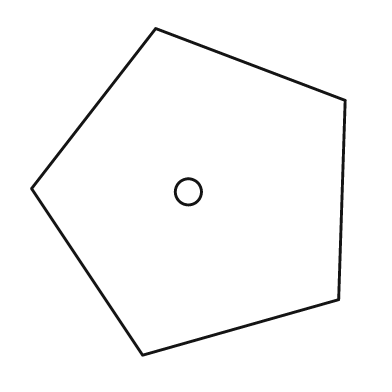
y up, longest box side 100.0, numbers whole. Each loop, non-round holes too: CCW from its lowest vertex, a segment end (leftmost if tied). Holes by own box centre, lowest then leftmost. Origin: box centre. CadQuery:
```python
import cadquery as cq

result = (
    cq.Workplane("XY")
    .moveTo(-14.0, -50.0)
    .lineTo(46.0, -33.0)
    .lineTo(48.0, 28.0)
    .lineTo(-10.0, 50.0)
    .lineTo(-48.0, 1.0)
    .close()
    .moveTo(0.0, 0.0)
    .circle(4.0)
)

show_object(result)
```